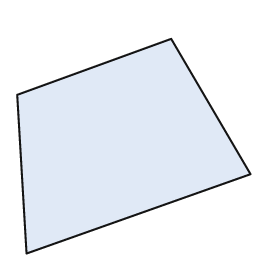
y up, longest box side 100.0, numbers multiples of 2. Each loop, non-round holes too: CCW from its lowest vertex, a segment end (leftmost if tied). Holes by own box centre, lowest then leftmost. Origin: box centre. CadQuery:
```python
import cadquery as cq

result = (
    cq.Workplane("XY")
    .moveTo(-46.0, -46.0)
    .lineTo(50.0, -12.0)
    .lineTo(16.0, 46.0)
    .lineTo(-50.0, 22.0)
    .close()
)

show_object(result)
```